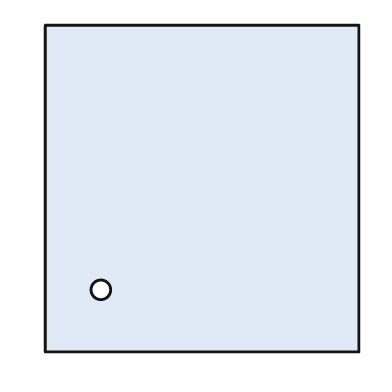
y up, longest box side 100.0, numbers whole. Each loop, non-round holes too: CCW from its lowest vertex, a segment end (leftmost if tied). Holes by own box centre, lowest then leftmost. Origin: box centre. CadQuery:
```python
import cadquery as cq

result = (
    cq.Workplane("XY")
    .moveTo(-48.0, -50.0)
    .lineTo(48.0, -50.0)
    .lineTo(48.0, 50.0)
    .lineTo(-48.0, 50.0)
    .close()
    .moveTo(-31.0, -31.0)
    .circle(3.0)
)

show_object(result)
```